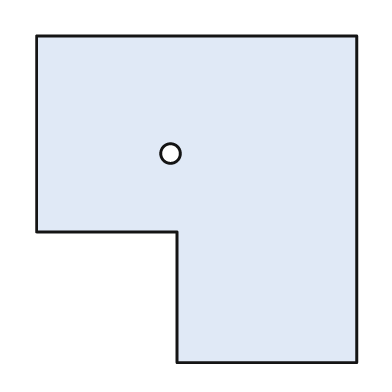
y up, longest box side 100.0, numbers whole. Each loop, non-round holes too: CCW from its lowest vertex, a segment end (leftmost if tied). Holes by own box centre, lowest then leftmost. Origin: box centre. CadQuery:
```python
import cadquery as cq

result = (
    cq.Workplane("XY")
    .moveTo(-6.0, -50.0)
    .lineTo(49.0, -50.0)
    .lineTo(49.0, 50.0)
    .lineTo(-49.0, 50.0)
    .lineTo(-49.0, -10.0)
    .lineTo(-6.0, -10.0)
    .close()
    .moveTo(-8.0, 14.0)
    .circle(3.0)
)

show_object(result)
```